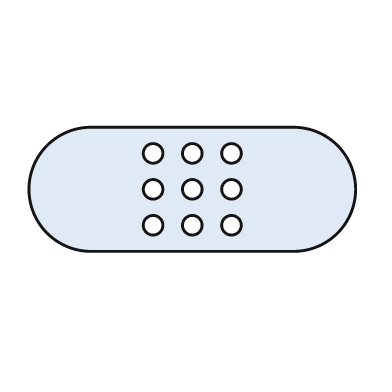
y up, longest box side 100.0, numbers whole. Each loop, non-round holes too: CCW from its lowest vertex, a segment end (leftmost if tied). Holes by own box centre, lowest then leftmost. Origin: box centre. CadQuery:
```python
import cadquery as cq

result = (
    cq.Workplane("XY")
    .moveTo(-31.0, -19.0)
    .lineTo(31.0, -19.0)
    .threePointArc((50.0, 0.0), (31.0, 19.0))
    .lineTo(-31.0, 19.0)
    .threePointArc((-50.0, 0.0), (-31.0, -19.0))
    .close()
    .moveTo(-12.0, -11.0)
    .circle(3.0)
    .moveTo(0.0, -11.0)
    .circle(3.0)
    .moveTo(12.0, -11.0)
    .circle(3.0)
    .moveTo(-12.0, 0.0)
    .circle(3.0)
    .moveTo(0.0, 0.0)
    .circle(3.0)
    .moveTo(12.0, 0.0)
    .circle(3.0)
    .moveTo(-12.0, 11.0)
    .circle(3.0)
    .moveTo(0.0, 11.0)
    .circle(3.0)
    .moveTo(12.0, 11.0)
    .circle(3.0)
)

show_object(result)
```